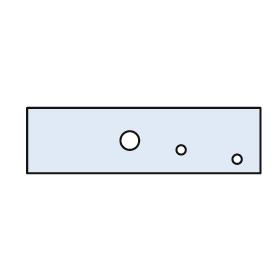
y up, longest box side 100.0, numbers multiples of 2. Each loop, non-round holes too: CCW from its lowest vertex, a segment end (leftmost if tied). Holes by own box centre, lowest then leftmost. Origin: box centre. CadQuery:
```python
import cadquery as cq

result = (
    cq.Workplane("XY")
    .moveTo(-50.0, -14.0)
    .lineTo(50.0, -14.0)
    .lineTo(50.0, 14.0)
    .lineTo(-50.0, 14.0)
    .close()
    .moveTo(40.0, -8.0)
    .circle(2.0)
    .moveTo(16.0, -4.0)
    .circle(2.0)
    .moveTo(-6.0, 0.0)
    .circle(4.0)
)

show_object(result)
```